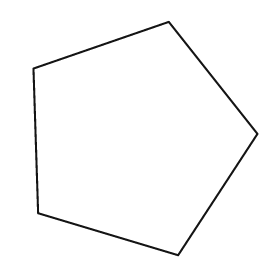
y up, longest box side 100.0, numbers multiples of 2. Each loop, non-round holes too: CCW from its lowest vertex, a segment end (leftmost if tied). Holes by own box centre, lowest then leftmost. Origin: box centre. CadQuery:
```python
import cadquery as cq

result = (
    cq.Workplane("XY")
    .moveTo(14.0, -50.0)
    .lineTo(48.0, 2.0)
    .lineTo(10.0, 50.0)
    .lineTo(-48.0, 30.0)
    .lineTo(-46.0, -32.0)
    .close()
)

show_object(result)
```